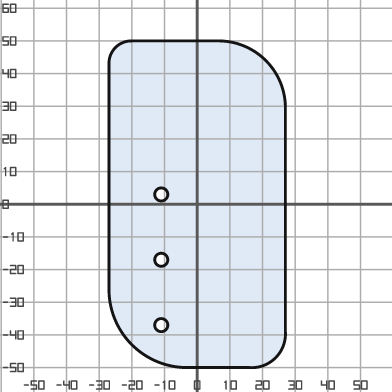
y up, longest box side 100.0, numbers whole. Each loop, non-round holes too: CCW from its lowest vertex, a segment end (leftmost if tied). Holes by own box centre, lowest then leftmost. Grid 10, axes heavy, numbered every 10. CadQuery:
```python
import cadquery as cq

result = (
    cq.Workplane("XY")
    .moveTo(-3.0, -50.0)
    .lineTo(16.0, -50.0)
    .threePointArc((24.0, -47.0), (27.0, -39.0))
    .lineTo(27.0, 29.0)
    .threePointArc((21.0, 44.0), (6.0, 50.0))
    .lineTo(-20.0, 50.0)
    .threePointArc((-25.0, 48.0), (-27.0, 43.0))
    .lineTo(-27.0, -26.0)
    .threePointArc((-20.0, -43.0), (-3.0, -50.0))
    .close()
    .moveTo(-11.0, -37.0)
    .circle(2.0)
    .moveTo(-11.0, -17.0)
    .circle(2.0)
    .moveTo(-11.0, 3.0)
    .circle(2.0)
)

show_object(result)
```